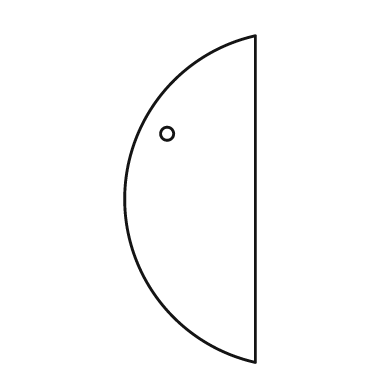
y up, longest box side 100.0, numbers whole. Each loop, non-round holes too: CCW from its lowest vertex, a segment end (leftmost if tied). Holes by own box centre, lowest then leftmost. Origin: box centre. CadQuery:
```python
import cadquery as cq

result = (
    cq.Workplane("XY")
    .moveTo(20.0, -50.0)
    .lineTo(20.0, 50.0)
    .threePointArc((-20.0, 0.0), (20.0, -50.0))
    .close()
    .moveTo(-7.0, 20.0)
    .circle(2.0)
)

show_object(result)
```